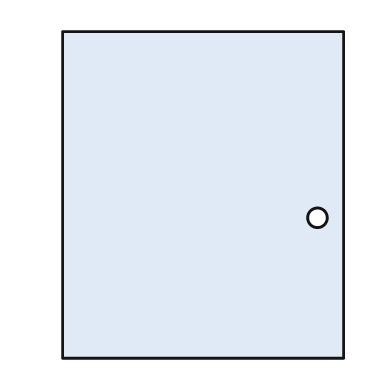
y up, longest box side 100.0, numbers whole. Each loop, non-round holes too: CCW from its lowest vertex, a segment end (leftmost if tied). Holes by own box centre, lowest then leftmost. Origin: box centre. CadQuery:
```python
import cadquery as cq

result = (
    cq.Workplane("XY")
    .moveTo(-43.0, -50.0)
    .lineTo(43.0, -50.0)
    .lineTo(43.0, 50.0)
    .lineTo(-43.0, 50.0)
    .close()
    .moveTo(35.0, -7.0)
    .circle(3.0)
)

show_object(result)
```